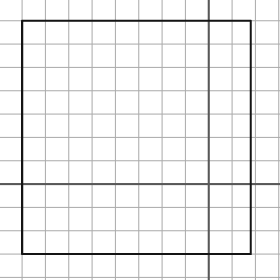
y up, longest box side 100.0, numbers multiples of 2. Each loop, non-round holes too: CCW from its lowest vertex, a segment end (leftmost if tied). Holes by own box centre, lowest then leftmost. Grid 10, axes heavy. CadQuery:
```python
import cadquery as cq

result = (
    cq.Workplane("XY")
    .moveTo(-80.0, -30.0)
    .lineTo(18.0, -30.0)
    .lineTo(18.0, 70.0)
    .lineTo(-80.0, 70.0)
    .close()
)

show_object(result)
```